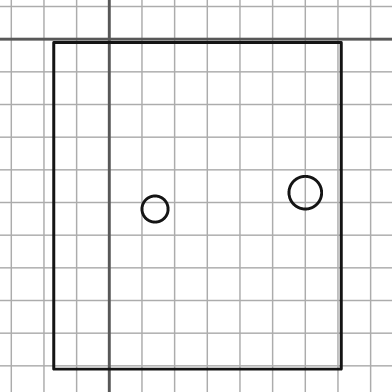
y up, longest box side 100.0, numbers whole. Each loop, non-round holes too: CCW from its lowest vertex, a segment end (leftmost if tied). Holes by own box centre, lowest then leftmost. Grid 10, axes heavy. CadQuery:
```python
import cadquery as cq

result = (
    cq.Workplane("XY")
    .moveTo(-17.0, -101.0)
    .lineTo(71.0, -101.0)
    .lineTo(71.0, -1.0)
    .lineTo(-17.0, -1.0)
    .close()
    .moveTo(14.0, -52.0)
    .circle(4.0)
    .moveTo(60.0, -47.0)
    .circle(5.0)
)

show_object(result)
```